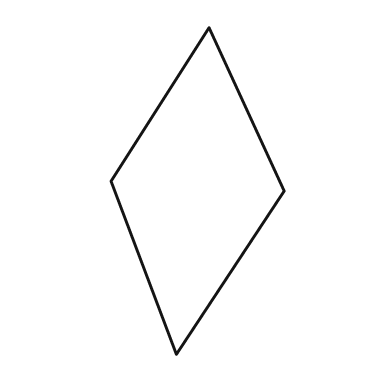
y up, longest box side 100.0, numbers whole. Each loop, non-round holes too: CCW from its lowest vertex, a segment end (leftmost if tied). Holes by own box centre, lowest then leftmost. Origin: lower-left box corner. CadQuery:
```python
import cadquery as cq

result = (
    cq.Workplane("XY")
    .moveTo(20.0, 0.0)
    .lineTo(53.0, 50.0)
    .lineTo(30.0, 100.0)
    .lineTo(0.0, 53.0)
    .close()
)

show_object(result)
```